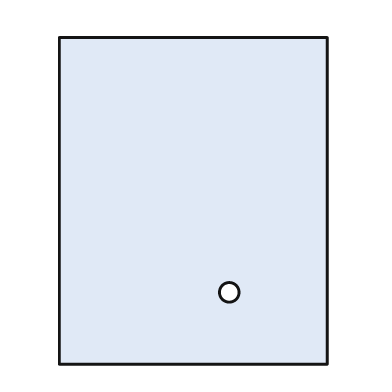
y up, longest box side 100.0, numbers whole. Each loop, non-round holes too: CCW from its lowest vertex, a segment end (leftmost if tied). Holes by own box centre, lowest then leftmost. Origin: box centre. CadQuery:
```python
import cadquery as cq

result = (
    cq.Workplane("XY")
    .moveTo(-41.0, -50.0)
    .lineTo(41.0, -50.0)
    .lineTo(41.0, 50.0)
    .lineTo(-41.0, 50.0)
    .close()
    .moveTo(11.0, -28.0)
    .circle(3.0)
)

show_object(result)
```